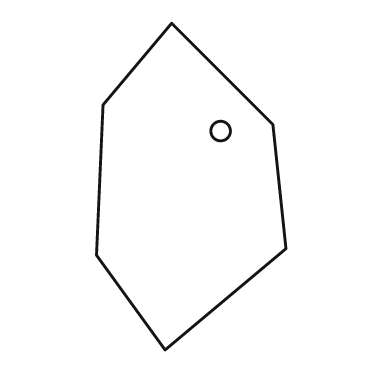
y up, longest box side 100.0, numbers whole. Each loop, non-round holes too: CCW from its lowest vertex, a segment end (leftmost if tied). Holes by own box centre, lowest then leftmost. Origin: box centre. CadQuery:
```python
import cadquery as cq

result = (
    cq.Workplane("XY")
    .moveTo(-8.0, -50.0)
    .lineTo(29.0, -19.0)
    .lineTo(25.0, 19.0)
    .lineTo(-6.0, 50.0)
    .lineTo(-27.0, 25.0)
    .lineTo(-29.0, -21.0)
    .close()
    .moveTo(9.0, 17.0)
    .circle(3.0)
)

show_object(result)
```